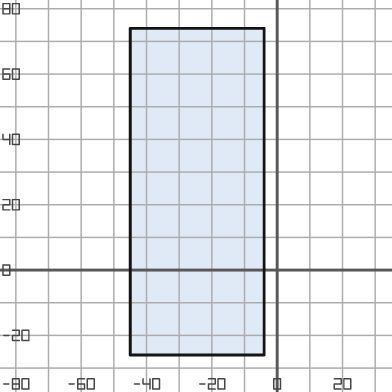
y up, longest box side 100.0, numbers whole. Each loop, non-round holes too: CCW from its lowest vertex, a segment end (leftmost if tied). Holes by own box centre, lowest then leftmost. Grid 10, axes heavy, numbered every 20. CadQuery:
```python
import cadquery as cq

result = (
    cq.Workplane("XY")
    .moveTo(-45.0, -26.0)
    .lineTo(-4.0, -26.0)
    .lineTo(-4.0, 74.0)
    .lineTo(-45.0, 74.0)
    .close()
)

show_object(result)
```